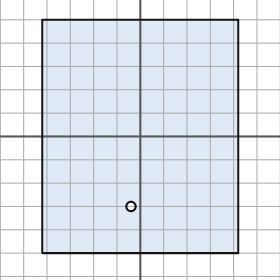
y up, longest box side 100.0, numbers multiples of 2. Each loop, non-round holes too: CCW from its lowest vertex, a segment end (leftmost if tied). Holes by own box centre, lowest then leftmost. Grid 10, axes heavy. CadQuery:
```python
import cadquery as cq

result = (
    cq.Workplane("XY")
    .moveTo(-42.0, -50.0)
    .lineTo(42.0, -50.0)
    .lineTo(42.0, 50.0)
    .lineTo(-42.0, 50.0)
    .close()
    .moveTo(-4.0, -30.0)
    .circle(2.0)
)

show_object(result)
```